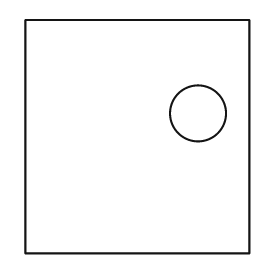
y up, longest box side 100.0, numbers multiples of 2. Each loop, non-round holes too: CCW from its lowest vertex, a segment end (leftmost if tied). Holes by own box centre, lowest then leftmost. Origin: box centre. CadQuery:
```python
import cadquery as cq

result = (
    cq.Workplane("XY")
    .moveTo(-48.0, -50.0)
    .lineTo(48.0, -50.0)
    .lineTo(48.0, 50.0)
    .lineTo(-48.0, 50.0)
    .close()
    .moveTo(26.0, 10.0)
    .circle(12.0)
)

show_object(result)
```